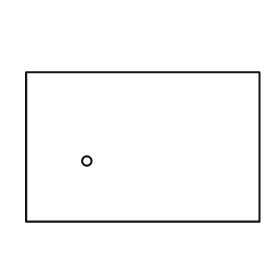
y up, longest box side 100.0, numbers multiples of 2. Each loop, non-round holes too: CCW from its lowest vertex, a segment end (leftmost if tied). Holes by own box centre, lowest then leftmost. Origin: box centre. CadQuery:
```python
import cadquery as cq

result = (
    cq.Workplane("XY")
    .moveTo(-50.0, -32.0)
    .lineTo(50.0, -32.0)
    .lineTo(50.0, 32.0)
    .lineTo(-50.0, 32.0)
    .close()
    .moveTo(-24.0, -6.0)
    .circle(2.0)
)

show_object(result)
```